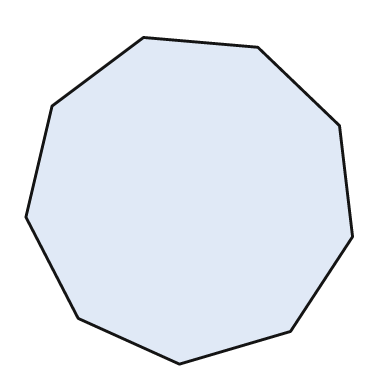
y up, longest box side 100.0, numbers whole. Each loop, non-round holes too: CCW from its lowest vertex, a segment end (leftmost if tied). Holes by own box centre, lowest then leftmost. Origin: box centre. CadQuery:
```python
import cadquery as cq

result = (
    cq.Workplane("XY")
    .moveTo(-3.0, -50.0)
    .lineTo(31.0, -40.0)
    .lineTo(50.0, -11.0)
    .lineTo(46.0, 23.0)
    .lineTo(21.0, 47.0)
    .lineTo(-14.0, 50.0)
    .lineTo(-42.0, 29.0)
    .lineTo(-50.0, -5.0)
    .lineTo(-34.0, -36.0)
    .close()
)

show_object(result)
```